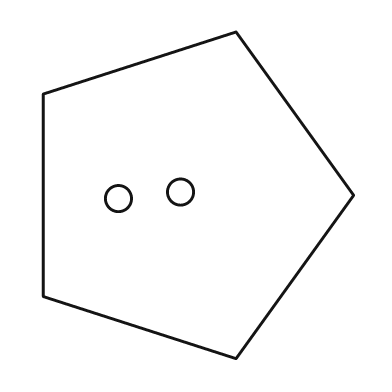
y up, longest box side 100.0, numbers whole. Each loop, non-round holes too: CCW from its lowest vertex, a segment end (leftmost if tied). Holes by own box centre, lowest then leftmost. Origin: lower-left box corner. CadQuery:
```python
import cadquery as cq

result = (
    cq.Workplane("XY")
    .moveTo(59.0, 0.0)
    .lineTo(95.0, 50.0)
    .lineTo(59.0, 100.0)
    .lineTo(0.0, 81.0)
    .lineTo(0.0, 19.0)
    .close()
    .moveTo(23.0, 49.0)
    .circle(4.0)
    .moveTo(42.0, 51.0)
    .circle(4.0)
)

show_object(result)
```